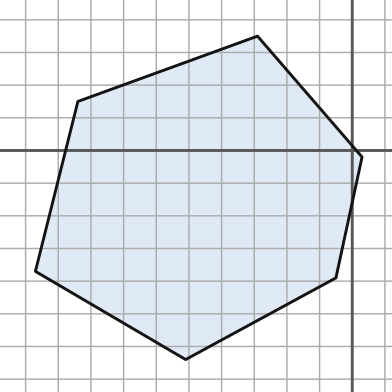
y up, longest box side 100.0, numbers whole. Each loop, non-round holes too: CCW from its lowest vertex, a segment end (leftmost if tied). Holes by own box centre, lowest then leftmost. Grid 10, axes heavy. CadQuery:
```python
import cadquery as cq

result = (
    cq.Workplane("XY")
    .moveTo(-51.0, -64.0)
    .lineTo(-5.0, -39.0)
    .lineTo(3.0, -2.0)
    .lineTo(-29.0, 35.0)
    .lineTo(-84.0, 15.0)
    .lineTo(-97.0, -37.0)
    .close()
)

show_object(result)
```